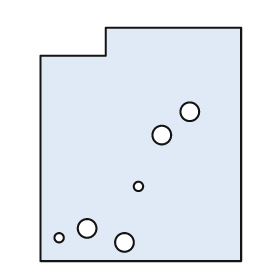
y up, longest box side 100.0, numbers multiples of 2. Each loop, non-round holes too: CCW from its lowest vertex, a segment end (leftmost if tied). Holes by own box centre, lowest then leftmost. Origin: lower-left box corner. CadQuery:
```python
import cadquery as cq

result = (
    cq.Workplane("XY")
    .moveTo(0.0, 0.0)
    .lineTo(86.0, 0.0)
    .lineTo(86.0, 100.0)
    .lineTo(28.0, 100.0)
    .lineTo(28.0, 88.0)
    .lineTo(0.0, 88.0)
    .close()
    .moveTo(36.0, 8.0)
    .circle(4.0)
    .moveTo(8.0, 10.0)
    .circle(2.0)
    .moveTo(20.0, 14.0)
    .circle(4.0)
    .moveTo(42.0, 32.0)
    .circle(2.0)
    .moveTo(52.0, 54.0)
    .circle(4.0)
    .moveTo(64.0, 64.0)
    .circle(4.0)
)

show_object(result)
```